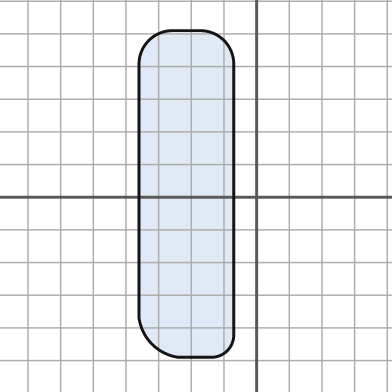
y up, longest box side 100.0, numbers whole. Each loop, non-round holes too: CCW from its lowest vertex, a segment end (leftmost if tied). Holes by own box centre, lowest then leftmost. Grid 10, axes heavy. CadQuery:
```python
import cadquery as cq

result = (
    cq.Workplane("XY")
    .moveTo(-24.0, -49.0)
    .lineTo(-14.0, -49.0)
    .threePointArc((-9.0, -47.0), (-7.0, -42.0))
    .lineTo(-7.0, 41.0)
    .threePointArc((-10.0, 48.0), (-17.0, 51.0))
    .lineTo(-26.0, 51.0)
    .threePointArc((-33.0, 48.0), (-36.0, 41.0))
    .lineTo(-36.0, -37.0)
    .threePointArc((-32.0, -45.0), (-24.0, -49.0))
    .close()
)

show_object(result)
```